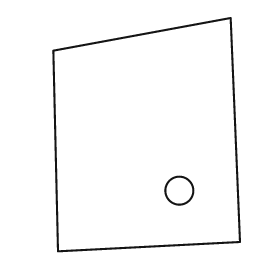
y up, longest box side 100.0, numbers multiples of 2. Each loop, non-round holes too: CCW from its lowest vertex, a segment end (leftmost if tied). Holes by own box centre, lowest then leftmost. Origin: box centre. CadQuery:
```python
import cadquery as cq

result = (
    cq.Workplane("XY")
    .moveTo(-38.0, -50.0)
    .lineTo(40.0, -46.0)
    .lineTo(36.0, 50.0)
    .lineTo(-40.0, 36.0)
    .close()
    .moveTo(14.0, -24.0)
    .circle(6.0)
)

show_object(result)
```